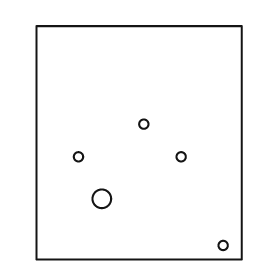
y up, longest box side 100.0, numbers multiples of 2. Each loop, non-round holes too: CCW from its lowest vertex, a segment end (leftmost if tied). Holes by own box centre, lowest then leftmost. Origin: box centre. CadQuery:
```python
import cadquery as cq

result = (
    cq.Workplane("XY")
    .moveTo(-44.0, -50.0)
    .lineTo(44.0, -50.0)
    .lineTo(44.0, 50.0)
    .lineTo(-44.0, 50.0)
    .close()
    .moveTo(36.0, -44.0)
    .circle(2.0)
    .moveTo(-16.0, -24.0)
    .circle(4.0)
    .moveTo(-26.0, -6.0)
    .circle(2.0)
    .moveTo(18.0, -6.0)
    .circle(2.0)
    .moveTo(2.0, 8.0)
    .circle(2.0)
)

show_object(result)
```